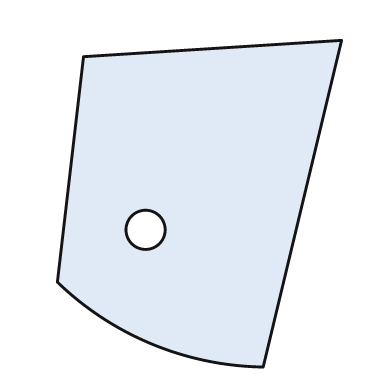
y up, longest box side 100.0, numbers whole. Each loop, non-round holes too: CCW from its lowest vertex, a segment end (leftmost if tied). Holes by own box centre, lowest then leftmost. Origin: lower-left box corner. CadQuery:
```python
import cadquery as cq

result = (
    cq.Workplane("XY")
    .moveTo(63.0, 0.0)
    .lineTo(87.0, 100.0)
    .lineTo(8.0, 95.0)
    .lineTo(0.0, 26.0)
    .threePointArc((29.0, 7.0), (63.0, 0.0))
    .close()
    .moveTo(27.0, 42.0)
    .circle(6.0)
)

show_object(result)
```